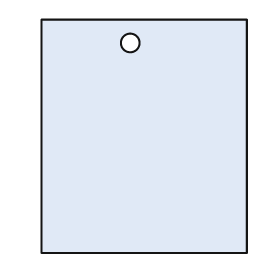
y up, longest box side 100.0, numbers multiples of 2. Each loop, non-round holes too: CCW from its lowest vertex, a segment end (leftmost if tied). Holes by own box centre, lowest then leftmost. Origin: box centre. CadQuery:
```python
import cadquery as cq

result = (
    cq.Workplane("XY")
    .moveTo(-44.0, -50.0)
    .lineTo(44.0, -50.0)
    .lineTo(44.0, 50.0)
    .lineTo(-44.0, 50.0)
    .close()
    .moveTo(-6.0, 40.0)
    .circle(4.0)
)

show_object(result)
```